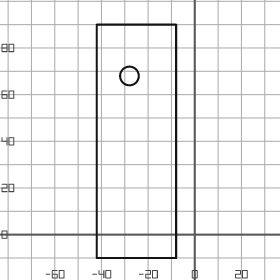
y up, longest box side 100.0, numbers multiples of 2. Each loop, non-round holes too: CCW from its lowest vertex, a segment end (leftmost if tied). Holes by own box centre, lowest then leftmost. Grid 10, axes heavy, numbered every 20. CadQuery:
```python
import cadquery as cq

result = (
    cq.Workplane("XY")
    .moveTo(-42.0, -10.0)
    .lineTo(-8.0, -10.0)
    .lineTo(-8.0, 90.0)
    .lineTo(-42.0, 90.0)
    .close()
    .moveTo(-28.0, 68.0)
    .circle(4.0)
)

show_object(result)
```